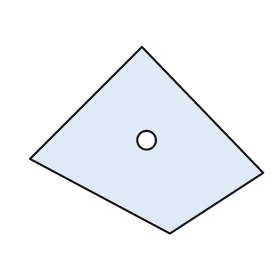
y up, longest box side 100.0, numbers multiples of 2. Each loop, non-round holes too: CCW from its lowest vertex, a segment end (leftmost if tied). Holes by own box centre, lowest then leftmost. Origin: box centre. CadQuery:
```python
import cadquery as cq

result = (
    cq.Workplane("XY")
    .moveTo(10.0, -40.0)
    .lineTo(50.0, -14.0)
    .lineTo(-2.0, 40.0)
    .lineTo(-50.0, -8.0)
    .close()
    .moveTo(0.0, 0.0)
    .circle(4.0)
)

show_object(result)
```